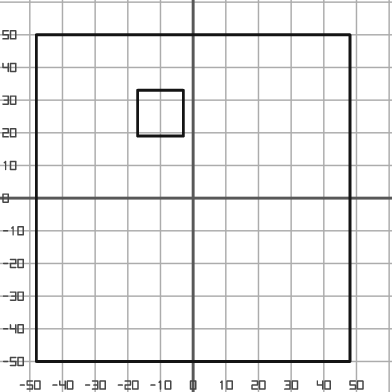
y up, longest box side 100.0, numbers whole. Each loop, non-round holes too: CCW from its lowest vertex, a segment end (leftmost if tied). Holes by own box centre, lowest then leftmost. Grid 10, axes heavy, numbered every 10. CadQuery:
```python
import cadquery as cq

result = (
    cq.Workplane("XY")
    .moveTo(-48.0, -50.0)
    .lineTo(48.0, -50.0)
    .lineTo(48.0, 50.0)
    .lineTo(-48.0, 50.0)
    .close()
    .moveTo(-17.0, 19.0)
    .lineTo(-3.0, 19.0)
    .lineTo(-3.0, 33.0)
    .lineTo(-17.0, 33.0)
    .close()
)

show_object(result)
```